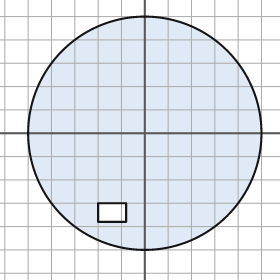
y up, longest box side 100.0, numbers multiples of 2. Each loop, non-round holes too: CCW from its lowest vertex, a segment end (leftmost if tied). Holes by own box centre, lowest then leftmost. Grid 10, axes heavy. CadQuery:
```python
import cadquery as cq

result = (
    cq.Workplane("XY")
    .moveTo(0.0, 0.0)
    .circle(50.0)
    .moveTo(-20.0, -38.0)
    .lineTo(-8.0, -38.0)
    .lineTo(-8.0, -30.0)
    .lineTo(-20.0, -30.0)
    .close()
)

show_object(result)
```